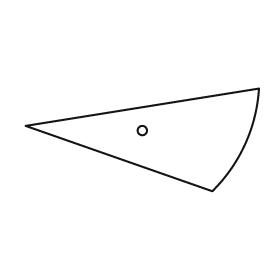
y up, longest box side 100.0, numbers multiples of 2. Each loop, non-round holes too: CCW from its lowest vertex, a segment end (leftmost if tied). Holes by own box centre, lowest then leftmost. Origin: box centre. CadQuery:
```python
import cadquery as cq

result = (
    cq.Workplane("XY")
    .moveTo(30.0, -22.0)
    .threePointArc((44.0, -2.0), (50.0, 22.0))
    .lineTo(-50.0, 6.0)
    .close()
    .moveTo(0.0, 4.0)
    .circle(2.0)
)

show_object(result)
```